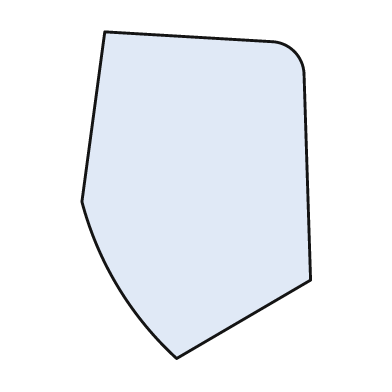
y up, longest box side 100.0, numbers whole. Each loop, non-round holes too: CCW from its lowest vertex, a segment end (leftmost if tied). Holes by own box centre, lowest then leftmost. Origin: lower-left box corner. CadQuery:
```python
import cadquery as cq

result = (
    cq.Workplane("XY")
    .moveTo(29.0, 0.0)
    .lineTo(70.0, 24.0)
    .lineTo(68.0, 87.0)
    .threePointArc((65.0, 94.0), (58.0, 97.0))
    .lineTo(7.0, 100.0)
    .lineTo(0.0, 48.0)
    .threePointArc((11.0, 22.0), (29.0, 0.0))
    .close()
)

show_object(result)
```